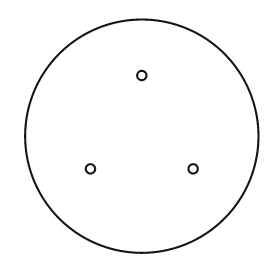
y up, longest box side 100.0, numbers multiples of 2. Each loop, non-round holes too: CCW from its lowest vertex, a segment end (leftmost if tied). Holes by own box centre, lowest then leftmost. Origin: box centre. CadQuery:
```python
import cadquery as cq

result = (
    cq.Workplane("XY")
    .moveTo(0.0, 0.0)
    .circle(50.0)
    .moveTo(-22.0, -14.0)
    .circle(2.0)
    .moveTo(22.0, -14.0)
    .circle(2.0)
    .moveTo(0.0, 26.0)
    .circle(2.0)
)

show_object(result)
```